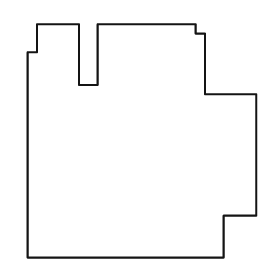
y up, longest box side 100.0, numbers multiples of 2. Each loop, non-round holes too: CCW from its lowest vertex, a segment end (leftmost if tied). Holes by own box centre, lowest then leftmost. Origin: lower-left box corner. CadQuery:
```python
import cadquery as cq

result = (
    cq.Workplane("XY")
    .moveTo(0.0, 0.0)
    .lineTo(84.0, 0.0)
    .lineTo(84.0, 18.0)
    .lineTo(98.0, 18.0)
    .lineTo(98.0, 70.0)
    .lineTo(76.0, 70.0)
    .lineTo(76.0, 96.0)
    .lineTo(72.0, 96.0)
    .lineTo(72.0, 100.0)
    .lineTo(30.0, 100.0)
    .lineTo(30.0, 74.0)
    .lineTo(22.0, 74.0)
    .lineTo(22.0, 100.0)
    .lineTo(4.0, 100.0)
    .lineTo(4.0, 88.0)
    .lineTo(0.0, 88.0)
    .close()
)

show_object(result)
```